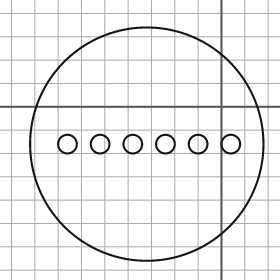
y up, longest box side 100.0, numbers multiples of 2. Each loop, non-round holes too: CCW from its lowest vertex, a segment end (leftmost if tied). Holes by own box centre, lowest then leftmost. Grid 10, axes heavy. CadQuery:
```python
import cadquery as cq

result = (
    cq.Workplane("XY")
    .moveTo(-32.0, -16.0)
    .circle(50.0)
    .moveTo(-66.0, -16.0)
    .circle(4.0)
    .moveTo(-52.0, -16.0)
    .circle(4.0)
    .moveTo(-38.0, -16.0)
    .circle(4.0)
    .moveTo(-24.0, -16.0)
    .circle(4.0)
    .moveTo(-10.0, -16.0)
    .circle(4.0)
    .moveTo(4.0, -16.0)
    .circle(4.0)
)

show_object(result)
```